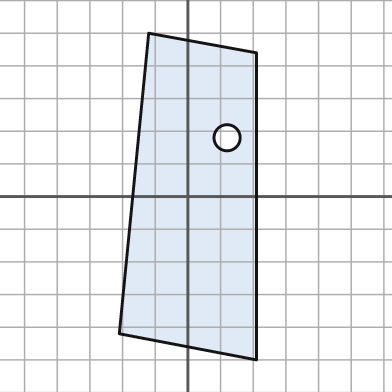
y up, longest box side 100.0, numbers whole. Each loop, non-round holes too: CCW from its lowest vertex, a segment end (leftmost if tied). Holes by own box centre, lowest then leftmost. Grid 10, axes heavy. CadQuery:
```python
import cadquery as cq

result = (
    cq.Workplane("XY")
    .moveTo(21.0, -50.0)
    .lineTo(21.0, 44.0)
    .lineTo(-12.0, 50.0)
    .lineTo(-21.0, -42.0)
    .close()
    .moveTo(12.0, 18.0)
    .circle(4.0)
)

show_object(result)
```